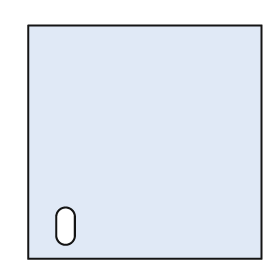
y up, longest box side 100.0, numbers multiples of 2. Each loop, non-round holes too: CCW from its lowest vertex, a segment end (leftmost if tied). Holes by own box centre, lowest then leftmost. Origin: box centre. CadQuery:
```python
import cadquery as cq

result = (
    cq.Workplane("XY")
    .moveTo(-50.0, -50.0)
    .lineTo(50.0, -50.0)
    .lineTo(50.0, 50.0)
    .lineTo(-50.0, 50.0)
    .close()
    .moveTo(-38.0, -40.0)
    .threePointArc((-34.0, -44.0), (-30.0, -40.0))
    .lineTo(-30.0, -32.0)
    .threePointArc((-34.0, -28.0), (-38.0, -32.0))
    .close()
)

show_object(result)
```